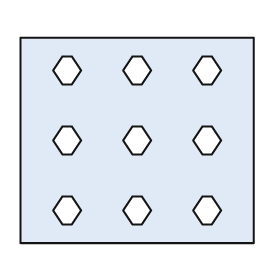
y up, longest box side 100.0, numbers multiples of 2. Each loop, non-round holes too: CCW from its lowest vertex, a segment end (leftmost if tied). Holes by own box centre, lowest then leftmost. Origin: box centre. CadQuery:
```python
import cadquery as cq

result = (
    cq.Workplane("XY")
    .moveTo(-50.0, -44.0)
    .lineTo(50.0, -44.0)
    .lineTo(50.0, 44.0)
    .lineTo(-50.0, 44.0)
    .close()
    .moveTo(-32.0, -36.0)
    .lineTo(-28.0, -36.0)
    .lineTo(-24.0, -30.0)
    .lineTo(-28.0, -24.0)
    .lineTo(-32.0, -24.0)
    .lineTo(-36.0, -30.0)
    .close()
    .moveTo(-2.0, -36.0)
    .lineTo(2.0, -36.0)
    .lineTo(6.0, -30.0)
    .lineTo(2.0, -24.0)
    .lineTo(-2.0, -24.0)
    .lineTo(-6.0, -30.0)
    .close()
    .moveTo(28.0, -36.0)
    .lineTo(32.0, -36.0)
    .lineTo(36.0, -30.0)
    .lineTo(32.0, -24.0)
    .lineTo(28.0, -24.0)
    .lineTo(24.0, -30.0)
    .close()
    .moveTo(-32.0, -6.0)
    .lineTo(-28.0, -6.0)
    .lineTo(-24.0, 0.0)
    .lineTo(-28.0, 6.0)
    .lineTo(-32.0, 6.0)
    .lineTo(-36.0, 0.0)
    .close()
    .moveTo(-2.0, -6.0)
    .lineTo(2.0, -6.0)
    .lineTo(6.0, 0.0)
    .lineTo(2.0, 6.0)
    .lineTo(-2.0, 6.0)
    .lineTo(-6.0, 0.0)
    .close()
    .moveTo(28.0, -6.0)
    .lineTo(32.0, -6.0)
    .lineTo(36.0, 0.0)
    .lineTo(32.0, 6.0)
    .lineTo(28.0, 6.0)
    .lineTo(24.0, 0.0)
    .close()
    .moveTo(-32.0, 24.0)
    .lineTo(-28.0, 24.0)
    .lineTo(-24.0, 30.0)
    .lineTo(-28.0, 36.0)
    .lineTo(-32.0, 36.0)
    .lineTo(-36.0, 30.0)
    .close()
    .moveTo(-2.0, 24.0)
    .lineTo(2.0, 24.0)
    .lineTo(6.0, 30.0)
    .lineTo(2.0, 36.0)
    .lineTo(-2.0, 36.0)
    .lineTo(-6.0, 30.0)
    .close()
    .moveTo(28.0, 24.0)
    .lineTo(32.0, 24.0)
    .lineTo(36.0, 30.0)
    .lineTo(32.0, 36.0)
    .lineTo(28.0, 36.0)
    .lineTo(24.0, 30.0)
    .close()
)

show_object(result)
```